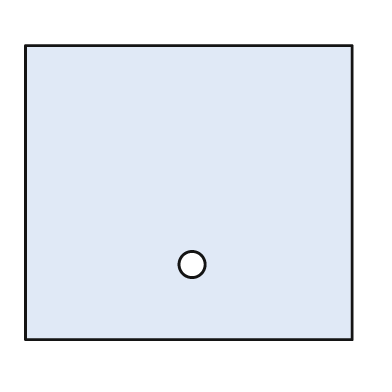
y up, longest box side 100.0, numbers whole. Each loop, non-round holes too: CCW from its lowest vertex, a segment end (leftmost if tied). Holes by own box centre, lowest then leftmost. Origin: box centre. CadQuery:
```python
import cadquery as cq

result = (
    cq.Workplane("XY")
    .moveTo(-50.0, -45.0)
    .lineTo(50.0, -45.0)
    .lineTo(50.0, 45.0)
    .lineTo(-50.0, 45.0)
    .close()
    .moveTo(1.0, -22.0)
    .circle(4.0)
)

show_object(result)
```